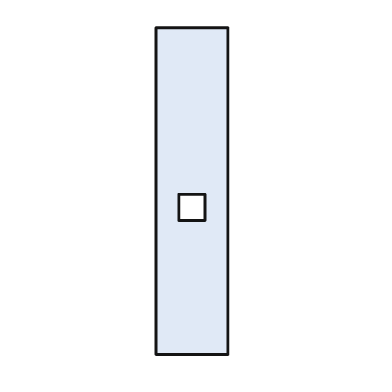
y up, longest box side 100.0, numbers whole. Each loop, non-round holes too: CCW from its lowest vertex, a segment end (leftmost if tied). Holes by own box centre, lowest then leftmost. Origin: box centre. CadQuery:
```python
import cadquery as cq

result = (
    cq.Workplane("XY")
    .moveTo(-11.0, -50.0)
    .lineTo(11.0, -50.0)
    .lineTo(11.0, 50.0)
    .lineTo(-11.0, 50.0)
    .close()
    .moveTo(-4.0, -9.0)
    .lineTo(4.0, -9.0)
    .lineTo(4.0, -1.0)
    .lineTo(-4.0, -1.0)
    .close()
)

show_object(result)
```